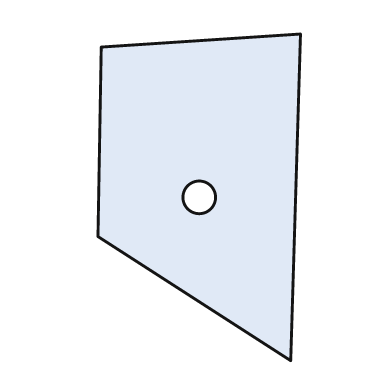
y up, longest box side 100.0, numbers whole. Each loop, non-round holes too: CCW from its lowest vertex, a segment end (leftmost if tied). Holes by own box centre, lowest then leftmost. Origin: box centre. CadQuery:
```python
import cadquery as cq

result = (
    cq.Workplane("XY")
    .moveTo(28.0, -50.0)
    .lineTo(31.0, 50.0)
    .lineTo(-30.0, 46.0)
    .lineTo(-31.0, -12.0)
    .close()
    .moveTo(0.0, 0.0)
    .circle(5.0)
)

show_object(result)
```